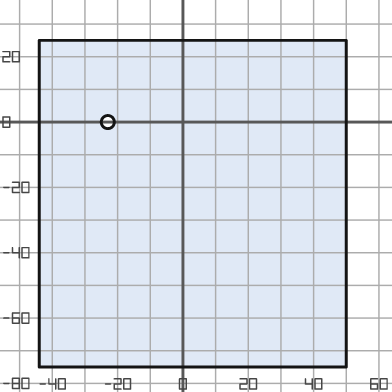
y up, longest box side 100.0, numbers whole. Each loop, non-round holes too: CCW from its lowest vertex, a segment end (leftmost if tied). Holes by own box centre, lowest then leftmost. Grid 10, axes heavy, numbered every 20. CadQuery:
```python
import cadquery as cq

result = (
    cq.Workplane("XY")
    .moveTo(-44.0, -75.0)
    .lineTo(50.0, -75.0)
    .lineTo(50.0, 25.0)
    .lineTo(-44.0, 25.0)
    .close()
    .moveTo(-23.0, 0.0)
    .circle(2.0)
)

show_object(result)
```